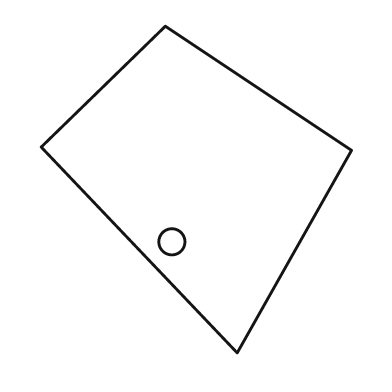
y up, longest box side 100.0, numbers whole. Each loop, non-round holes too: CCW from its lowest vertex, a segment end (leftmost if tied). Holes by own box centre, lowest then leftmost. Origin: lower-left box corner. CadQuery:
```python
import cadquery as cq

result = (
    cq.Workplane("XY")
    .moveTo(60.0, 0.0)
    .lineTo(95.0, 62.0)
    .lineTo(38.0, 100.0)
    .lineTo(0.0, 63.0)
    .close()
    .moveTo(40.0, 34.0)
    .circle(4.0)
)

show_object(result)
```